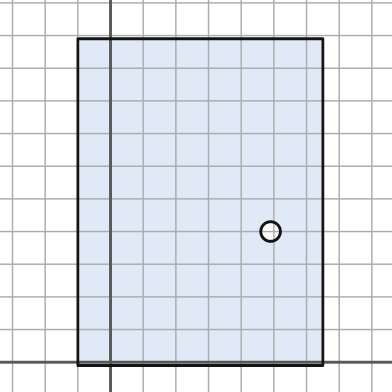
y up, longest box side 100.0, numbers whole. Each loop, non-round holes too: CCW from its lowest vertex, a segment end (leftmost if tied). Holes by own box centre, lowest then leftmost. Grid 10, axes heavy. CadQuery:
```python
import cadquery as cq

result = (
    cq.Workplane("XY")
    .moveTo(-10.0, -1.0)
    .lineTo(65.0, -1.0)
    .lineTo(65.0, 99.0)
    .lineTo(-10.0, 99.0)
    .close()
    .moveTo(49.0, 40.0)
    .circle(3.0)
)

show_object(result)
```